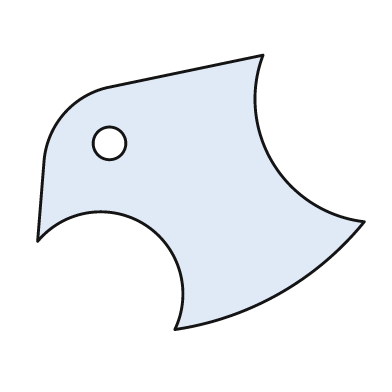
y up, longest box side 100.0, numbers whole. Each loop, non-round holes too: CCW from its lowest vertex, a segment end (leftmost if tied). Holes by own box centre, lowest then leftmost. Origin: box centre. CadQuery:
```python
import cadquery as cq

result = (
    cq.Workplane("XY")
    .moveTo(-8.0, -42.0)
    .threePointArc((24.0, -31.0), (50.0, -9.0))
    .threePointArc((22.0, 9.0), (19.0, 42.0))
    .lineTo(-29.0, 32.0)
    .threePointArc((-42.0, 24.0), (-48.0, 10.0))
    .lineTo(-50.0, -15.0)
    .threePointArc((-17.0, -10.0), (-8.0, -42.0))
    .close()
    .moveTo(-28.0, 15.0)
    .circle(5.0)
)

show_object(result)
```